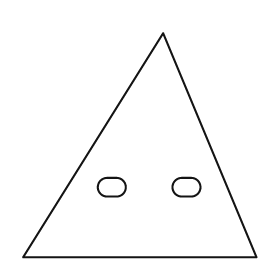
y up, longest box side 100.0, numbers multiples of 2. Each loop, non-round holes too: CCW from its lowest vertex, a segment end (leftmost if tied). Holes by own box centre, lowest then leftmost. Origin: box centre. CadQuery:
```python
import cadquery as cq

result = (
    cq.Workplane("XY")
    .moveTo(-50.0, -48.0)
    .lineTo(50.0, -48.0)
    .lineTo(10.0, 48.0)
    .close()
    .moveTo(-14.0, -22.0)
    .lineTo(-10.0, -22.0)
    .threePointArc((-6.0, -18.0), (-10.0, -14.0))
    .lineTo(-14.0, -14.0)
    .threePointArc((-18.0, -18.0), (-14.0, -22.0))
    .close()
    .moveTo(18.0, -22.0)
    .lineTo(22.0, -22.0)
    .threePointArc((26.0, -18.0), (22.0, -14.0))
    .lineTo(18.0, -14.0)
    .threePointArc((14.0, -18.0), (18.0, -22.0))
    .close()
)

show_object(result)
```